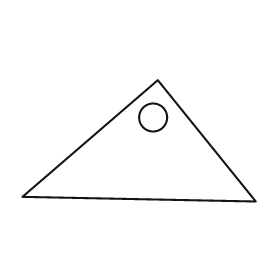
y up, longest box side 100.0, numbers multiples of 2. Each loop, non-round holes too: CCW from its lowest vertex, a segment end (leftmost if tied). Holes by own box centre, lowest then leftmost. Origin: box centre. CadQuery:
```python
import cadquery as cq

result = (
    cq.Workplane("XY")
    .moveTo(50.0, -26.0)
    .lineTo(8.0, 26.0)
    .lineTo(-50.0, -24.0)
    .close()
    .moveTo(6.0, 10.0)
    .circle(6.0)
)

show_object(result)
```